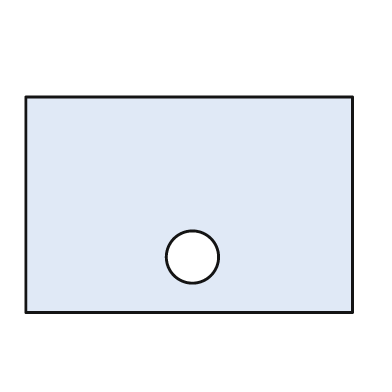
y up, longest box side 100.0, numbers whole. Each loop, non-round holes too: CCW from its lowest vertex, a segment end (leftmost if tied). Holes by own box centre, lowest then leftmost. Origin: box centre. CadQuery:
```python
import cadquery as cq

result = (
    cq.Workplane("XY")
    .moveTo(-50.0, -33.0)
    .lineTo(50.0, -33.0)
    .lineTo(50.0, 33.0)
    .lineTo(-50.0, 33.0)
    .close()
    .moveTo(1.0, -16.0)
    .circle(8.0)
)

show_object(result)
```